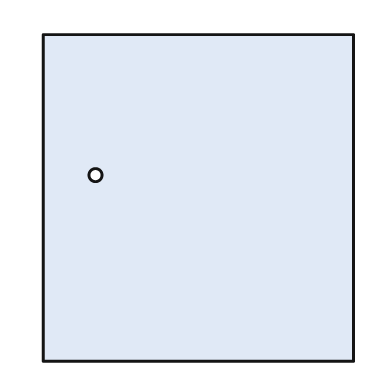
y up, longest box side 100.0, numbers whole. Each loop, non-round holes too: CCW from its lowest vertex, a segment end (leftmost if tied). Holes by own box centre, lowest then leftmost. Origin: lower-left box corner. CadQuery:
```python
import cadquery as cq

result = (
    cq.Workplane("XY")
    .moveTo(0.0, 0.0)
    .lineTo(95.0, 0.0)
    .lineTo(95.0, 100.0)
    .lineTo(0.0, 100.0)
    .close()
    .moveTo(16.0, 57.0)
    .circle(2.0)
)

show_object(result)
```